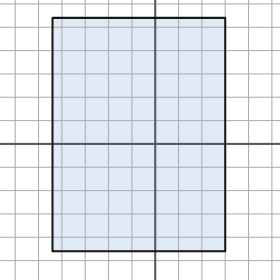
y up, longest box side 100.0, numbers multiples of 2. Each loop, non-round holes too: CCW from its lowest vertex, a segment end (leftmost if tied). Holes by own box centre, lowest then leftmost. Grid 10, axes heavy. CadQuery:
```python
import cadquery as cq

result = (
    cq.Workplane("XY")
    .moveTo(-44.0, -46.0)
    .lineTo(30.0, -46.0)
    .lineTo(30.0, 54.0)
    .lineTo(-44.0, 54.0)
    .close()
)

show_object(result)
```